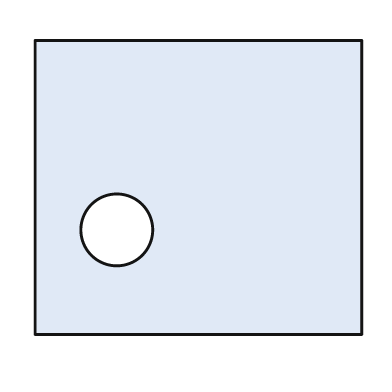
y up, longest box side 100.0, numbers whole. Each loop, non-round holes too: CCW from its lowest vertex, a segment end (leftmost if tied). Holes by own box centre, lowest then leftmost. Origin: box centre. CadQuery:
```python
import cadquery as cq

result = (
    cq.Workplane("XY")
    .moveTo(-50.0, -45.0)
    .lineTo(50.0, -45.0)
    .lineTo(50.0, 45.0)
    .lineTo(-50.0, 45.0)
    .close()
    .moveTo(-25.0, -13.0)
    .circle(11.0)
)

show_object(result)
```